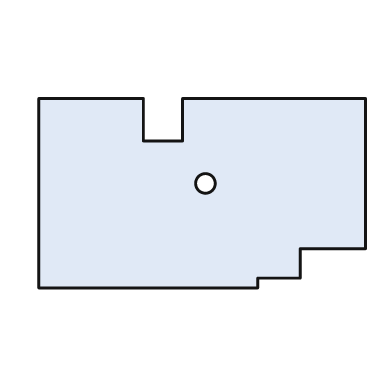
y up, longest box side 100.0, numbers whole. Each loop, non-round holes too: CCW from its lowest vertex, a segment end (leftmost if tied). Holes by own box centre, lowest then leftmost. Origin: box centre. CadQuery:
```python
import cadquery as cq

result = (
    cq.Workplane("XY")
    .moveTo(-50.0, -29.0)
    .lineTo(17.0, -29.0)
    .lineTo(17.0, -26.0)
    .lineTo(30.0, -26.0)
    .lineTo(30.0, -17.0)
    .lineTo(50.0, -17.0)
    .lineTo(50.0, 29.0)
    .lineTo(-6.0, 29.0)
    .lineTo(-6.0, 16.0)
    .lineTo(-18.0, 16.0)
    .lineTo(-18.0, 29.0)
    .lineTo(-50.0, 29.0)
    .close()
    .moveTo(1.0, 3.0)
    .circle(3.0)
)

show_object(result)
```